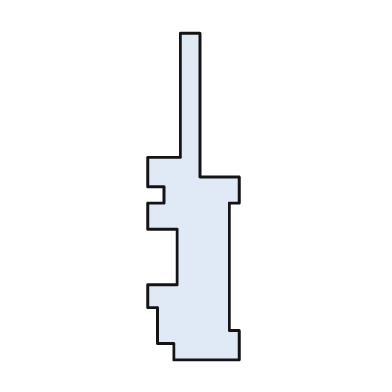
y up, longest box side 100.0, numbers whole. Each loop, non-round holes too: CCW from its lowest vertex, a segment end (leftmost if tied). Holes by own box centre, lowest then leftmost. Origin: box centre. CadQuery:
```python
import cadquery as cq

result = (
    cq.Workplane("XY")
    .moveTo(-6.0, -50.0)
    .lineTo(14.0, -50.0)
    .lineTo(14.0, -41.0)
    .lineTo(11.0, -41.0)
    .lineTo(11.0, -2.0)
    .lineTo(14.0, -2.0)
    .lineTo(14.0, 6.0)
    .lineTo(2.0, 6.0)
    .lineTo(2.0, 50.0)
    .lineTo(-4.0, 50.0)
    .lineTo(-4.0, 12.0)
    .lineTo(-14.0, 12.0)
    .lineTo(-14.0, 3.0)
    .lineTo(-9.0, 3.0)
    .lineTo(-9.0, -2.0)
    .lineTo(-14.0, -2.0)
    .lineTo(-14.0, -10.0)
    .lineTo(-5.0, -10.0)
    .lineTo(-5.0, -27.0)
    .lineTo(-14.0, -27.0)
    .lineTo(-14.0, -34.0)
    .lineTo(-11.0, -34.0)
    .lineTo(-11.0, -45.0)
    .lineTo(-6.0, -45.0)
    .close()
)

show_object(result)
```